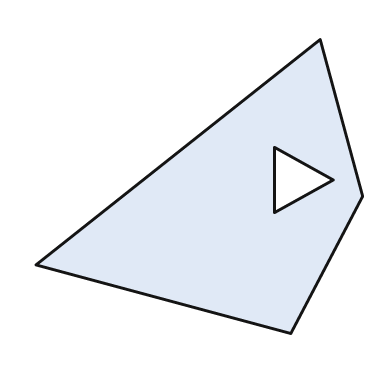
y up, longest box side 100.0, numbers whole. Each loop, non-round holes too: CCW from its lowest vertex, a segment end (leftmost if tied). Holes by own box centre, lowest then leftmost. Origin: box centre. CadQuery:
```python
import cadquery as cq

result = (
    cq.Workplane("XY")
    .moveTo(28.0, -45.0)
    .lineTo(50.0, -3.0)
    .lineTo(37.0, 45.0)
    .lineTo(-50.0, -24.0)
    .close()
    .moveTo(23.0, -8.0)
    .lineTo(41.0, 2.0)
    .lineTo(23.0, 12.0)
    .close()
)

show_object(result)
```